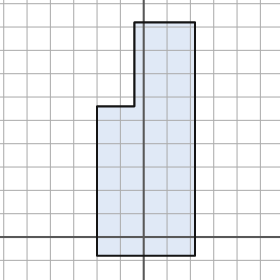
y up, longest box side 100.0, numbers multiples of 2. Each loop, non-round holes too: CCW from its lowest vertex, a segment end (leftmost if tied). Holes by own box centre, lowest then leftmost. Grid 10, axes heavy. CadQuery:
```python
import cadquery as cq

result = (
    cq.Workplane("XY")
    .moveTo(-20.0, -8.0)
    .lineTo(22.0, -8.0)
    .lineTo(22.0, 92.0)
    .lineTo(-4.0, 92.0)
    .lineTo(-4.0, 56.0)
    .lineTo(-20.0, 56.0)
    .close()
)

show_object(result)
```